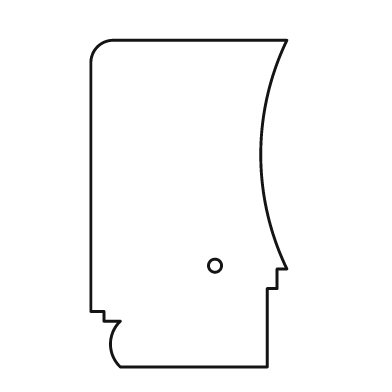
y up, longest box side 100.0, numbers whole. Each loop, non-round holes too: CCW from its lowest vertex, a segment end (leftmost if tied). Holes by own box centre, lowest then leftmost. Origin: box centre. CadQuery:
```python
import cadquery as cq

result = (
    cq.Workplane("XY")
    .moveTo(-21.0, -50.0)
    .lineTo(24.0, -50.0)
    .lineTo(24.0, -26.0)
    .lineTo(27.0, -26.0)
    .lineTo(27.0, -20.0)
    .lineTo(30.0, -20.0)
    .threePointArc((22.0, 15.0), (30.0, 50.0))
    .lineTo(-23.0, 50.0)
    .threePointArc((-28.0, 48.0), (-30.0, 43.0))
    .lineTo(-30.0, -33.0)
    .lineTo(-26.0, -33.0)
    .lineTo(-26.0, -36.0)
    .lineTo(-21.0, -36.0)
    .threePointArc((-24.0, -43.0), (-21.0, -50.0))
    .close()
    .moveTo(8.0, -19.0)
    .circle(2.0)
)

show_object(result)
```